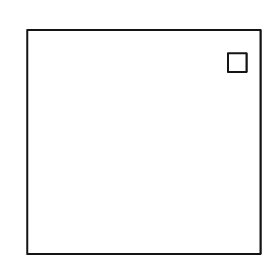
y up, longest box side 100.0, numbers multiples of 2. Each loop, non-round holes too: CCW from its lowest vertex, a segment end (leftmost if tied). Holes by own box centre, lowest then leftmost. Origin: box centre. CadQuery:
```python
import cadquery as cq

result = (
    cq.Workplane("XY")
    .moveTo(-50.0, -48.0)
    .lineTo(50.0, -48.0)
    .lineTo(50.0, 48.0)
    .lineTo(-50.0, 48.0)
    .close()
    .moveTo(36.0, 30.0)
    .lineTo(44.0, 30.0)
    .lineTo(44.0, 38.0)
    .lineTo(36.0, 38.0)
    .close()
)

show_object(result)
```